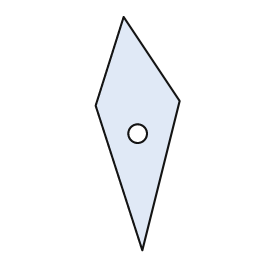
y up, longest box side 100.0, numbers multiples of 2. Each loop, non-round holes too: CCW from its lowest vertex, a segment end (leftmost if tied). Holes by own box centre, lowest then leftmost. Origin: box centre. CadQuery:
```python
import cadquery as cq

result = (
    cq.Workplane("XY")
    .moveTo(2.0, -50.0)
    .lineTo(18.0, 14.0)
    .lineTo(-6.0, 50.0)
    .lineTo(-18.0, 12.0)
    .close()
    .moveTo(0.0, 0.0)
    .circle(4.0)
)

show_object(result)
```